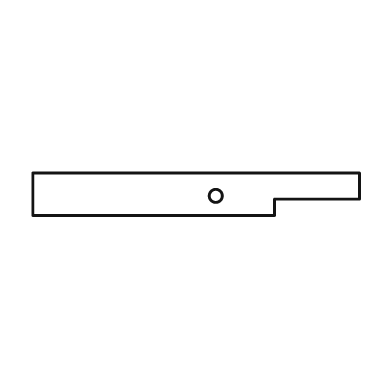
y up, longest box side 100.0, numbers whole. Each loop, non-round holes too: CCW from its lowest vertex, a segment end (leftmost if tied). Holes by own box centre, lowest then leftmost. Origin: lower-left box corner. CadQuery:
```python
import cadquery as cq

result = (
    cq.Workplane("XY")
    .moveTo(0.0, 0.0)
    .lineTo(74.0, 0.0)
    .lineTo(74.0, 5.0)
    .lineTo(100.0, 5.0)
    .lineTo(100.0, 13.0)
    .lineTo(0.0, 13.0)
    .close()
    .moveTo(56.0, 6.0)
    .circle(2.0)
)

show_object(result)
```